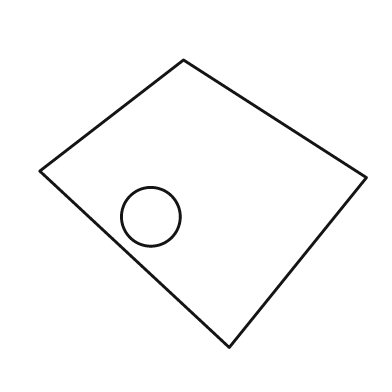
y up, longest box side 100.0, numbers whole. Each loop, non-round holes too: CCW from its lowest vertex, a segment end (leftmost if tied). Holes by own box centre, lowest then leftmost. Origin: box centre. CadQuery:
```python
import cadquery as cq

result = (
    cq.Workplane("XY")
    .moveTo(8.0, -44.0)
    .lineTo(50.0, 8.0)
    .lineTo(-6.0, 44.0)
    .lineTo(-50.0, 10.0)
    .close()
    .moveTo(-16.0, -4.0)
    .circle(9.0)
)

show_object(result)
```